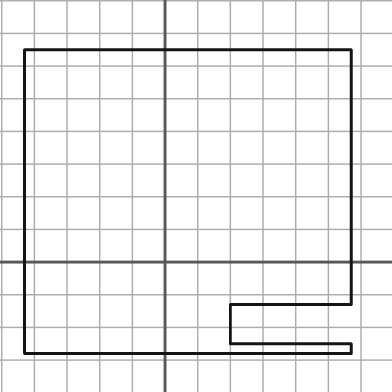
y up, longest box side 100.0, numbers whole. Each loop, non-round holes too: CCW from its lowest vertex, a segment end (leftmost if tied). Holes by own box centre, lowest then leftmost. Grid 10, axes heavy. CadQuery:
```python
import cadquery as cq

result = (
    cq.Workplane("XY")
    .moveTo(-43.0, -28.0)
    .lineTo(57.0, -28.0)
    .lineTo(57.0, -25.0)
    .lineTo(20.0, -25.0)
    .lineTo(20.0, -13.0)
    .lineTo(57.0, -13.0)
    .lineTo(57.0, 65.0)
    .lineTo(-43.0, 65.0)
    .close()
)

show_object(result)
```